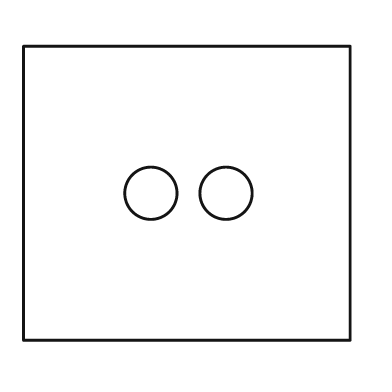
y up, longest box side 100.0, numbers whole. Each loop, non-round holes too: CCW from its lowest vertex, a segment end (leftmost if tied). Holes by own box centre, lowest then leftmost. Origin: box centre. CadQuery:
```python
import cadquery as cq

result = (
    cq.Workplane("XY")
    .moveTo(-50.0, -45.0)
    .lineTo(50.0, -45.0)
    .lineTo(50.0, 45.0)
    .lineTo(-50.0, 45.0)
    .close()
    .moveTo(-11.0, 0.0)
    .circle(8.0)
    .moveTo(12.0, 0.0)
    .circle(8.0)
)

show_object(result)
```